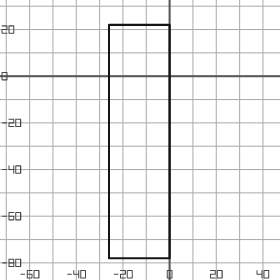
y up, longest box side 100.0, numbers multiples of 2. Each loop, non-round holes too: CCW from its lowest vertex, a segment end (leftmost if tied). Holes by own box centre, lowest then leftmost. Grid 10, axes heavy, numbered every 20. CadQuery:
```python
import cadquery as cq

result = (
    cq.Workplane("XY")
    .moveTo(-26.0, -78.0)
    .lineTo(0.0, -78.0)
    .lineTo(0.0, 22.0)
    .lineTo(-26.0, 22.0)
    .close()
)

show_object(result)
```